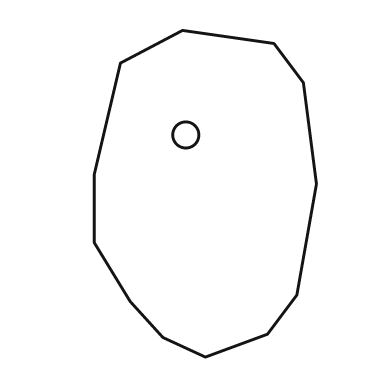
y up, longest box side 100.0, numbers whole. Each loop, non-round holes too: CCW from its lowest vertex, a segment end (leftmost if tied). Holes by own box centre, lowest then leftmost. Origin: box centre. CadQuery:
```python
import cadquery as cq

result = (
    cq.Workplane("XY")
    .moveTo(0.0, -50.0)
    .lineTo(19.0, -43.0)
    .lineTo(28.0, -31.0)
    .lineTo(34.0, 3.0)
    .lineTo(30.0, 34.0)
    .lineTo(21.0, 46.0)
    .lineTo(-7.0, 50.0)
    .lineTo(-26.0, 40.0)
    .lineTo(-34.0, 6.0)
    .lineTo(-34.0, -15.0)
    .lineTo(-23.0, -33.0)
    .lineTo(-13.0, -44.0)
    .close()
    .moveTo(-6.0, 18.0)
    .circle(4.0)
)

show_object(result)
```